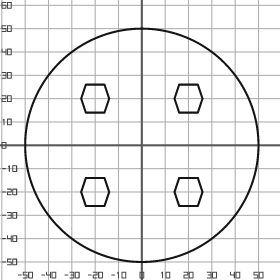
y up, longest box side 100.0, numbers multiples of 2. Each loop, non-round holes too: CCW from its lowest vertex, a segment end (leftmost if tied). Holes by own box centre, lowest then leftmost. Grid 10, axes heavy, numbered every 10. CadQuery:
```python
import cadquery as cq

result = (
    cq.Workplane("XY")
    .moveTo(0.0, 0.0)
    .circle(50.0)
    .moveTo(-24.0, -26.0)
    .lineTo(-16.0, -26.0)
    .lineTo(-14.0, -20.0)
    .lineTo(-16.0, -14.0)
    .lineTo(-24.0, -14.0)
    .lineTo(-26.0, -20.0)
    .close()
    .moveTo(16.0, -26.0)
    .lineTo(24.0, -26.0)
    .lineTo(26.0, -20.0)
    .lineTo(24.0, -14.0)
    .lineTo(16.0, -14.0)
    .lineTo(14.0, -20.0)
    .close()
    .moveTo(-24.0, 14.0)
    .lineTo(-16.0, 14.0)
    .lineTo(-14.0, 20.0)
    .lineTo(-16.0, 26.0)
    .lineTo(-24.0, 26.0)
    .lineTo(-26.0, 20.0)
    .close()
    .moveTo(16.0, 14.0)
    .lineTo(24.0, 14.0)
    .lineTo(26.0, 20.0)
    .lineTo(24.0, 26.0)
    .lineTo(16.0, 26.0)
    .lineTo(14.0, 20.0)
    .close()
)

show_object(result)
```